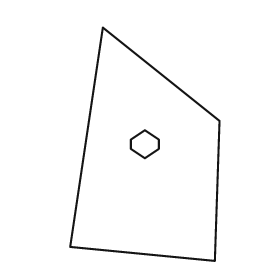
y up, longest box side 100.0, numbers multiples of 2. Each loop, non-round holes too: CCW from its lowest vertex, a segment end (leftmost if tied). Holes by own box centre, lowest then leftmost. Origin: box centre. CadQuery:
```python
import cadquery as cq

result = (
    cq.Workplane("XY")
    .moveTo(30.0, -50.0)
    .lineTo(32.0, 10.0)
    .lineTo(-18.0, 50.0)
    .lineTo(-32.0, -44.0)
    .close()
    .moveTo(0.0, -6.0)
    .lineTo(6.0, -2.0)
    .lineTo(6.0, 2.0)
    .lineTo(0.0, 6.0)
    .lineTo(-6.0, 2.0)
    .lineTo(-6.0, -2.0)
    .close()
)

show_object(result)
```